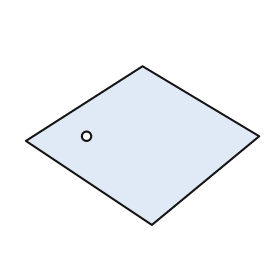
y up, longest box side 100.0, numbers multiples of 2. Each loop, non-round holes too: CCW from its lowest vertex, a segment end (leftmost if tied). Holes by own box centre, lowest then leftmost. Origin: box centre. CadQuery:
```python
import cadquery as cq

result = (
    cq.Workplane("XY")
    .moveTo(4.0, -34.0)
    .lineTo(50.0, 4.0)
    .lineTo(0.0, 34.0)
    .lineTo(-50.0, 2.0)
    .close()
    .moveTo(-24.0, 4.0)
    .circle(2.0)
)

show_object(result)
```